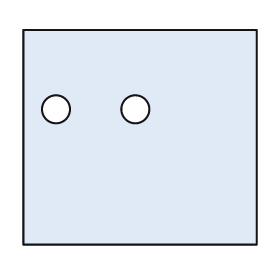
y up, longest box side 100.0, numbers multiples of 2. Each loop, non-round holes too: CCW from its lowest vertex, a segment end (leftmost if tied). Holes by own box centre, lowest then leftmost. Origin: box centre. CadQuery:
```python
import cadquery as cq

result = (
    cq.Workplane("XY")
    .moveTo(-50.0, -46.0)
    .lineTo(50.0, -46.0)
    .lineTo(50.0, 46.0)
    .lineTo(-50.0, 46.0)
    .close()
    .moveTo(-36.0, 12.0)
    .circle(6.0)
    .moveTo(-2.0, 12.0)
    .circle(6.0)
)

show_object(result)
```